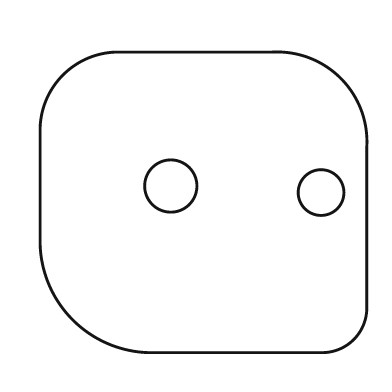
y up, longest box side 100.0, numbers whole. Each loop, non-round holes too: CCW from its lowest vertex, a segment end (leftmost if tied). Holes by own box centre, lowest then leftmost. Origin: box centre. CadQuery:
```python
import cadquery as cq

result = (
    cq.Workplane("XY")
    .moveTo(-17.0, -46.0)
    .lineTo(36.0, -46.0)
    .threePointArc((46.0, -42.0), (50.0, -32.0))
    .lineTo(50.0, 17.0)
    .threePointArc((42.0, 38.0), (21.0, 46.0))
    .lineTo(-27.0, 46.0)
    .threePointArc((-43.0, 39.0), (-50.0, 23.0))
    .lineTo(-50.0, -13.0)
    .threePointArc((-40.0, -36.0), (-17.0, -46.0))
    .close()
    .moveTo(36.0, 3.0)
    .circle(7.0)
    .moveTo(-10.0, 5.0)
    .circle(8.0)
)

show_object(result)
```